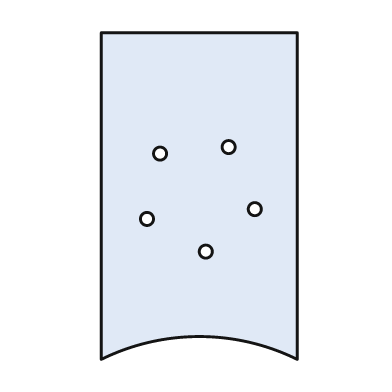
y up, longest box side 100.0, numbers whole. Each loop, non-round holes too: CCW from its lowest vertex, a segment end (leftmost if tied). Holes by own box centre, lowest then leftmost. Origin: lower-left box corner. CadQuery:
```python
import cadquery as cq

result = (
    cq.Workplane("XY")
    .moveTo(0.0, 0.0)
    .threePointArc((30.0, 7.0), (60.0, 0.0))
    .lineTo(60.0, 100.0)
    .lineTo(0.0, 100.0)
    .close()
    .moveTo(32.0, 33.0)
    .circle(2.0)
    .moveTo(14.0, 43.0)
    .circle(2.0)
    .moveTo(47.0, 46.0)
    .circle(2.0)
    .moveTo(18.0, 63.0)
    .circle(2.0)
    .moveTo(39.0, 65.0)
    .circle(2.0)
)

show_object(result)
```